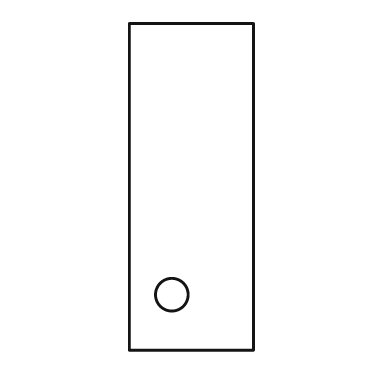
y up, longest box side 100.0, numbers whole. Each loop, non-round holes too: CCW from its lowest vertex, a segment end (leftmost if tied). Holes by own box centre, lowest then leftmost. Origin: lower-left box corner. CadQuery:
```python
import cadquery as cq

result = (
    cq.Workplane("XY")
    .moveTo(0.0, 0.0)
    .lineTo(38.0, 0.0)
    .lineTo(38.0, 100.0)
    .lineTo(0.0, 100.0)
    .close()
    .moveTo(13.0, 17.0)
    .circle(5.0)
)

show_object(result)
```